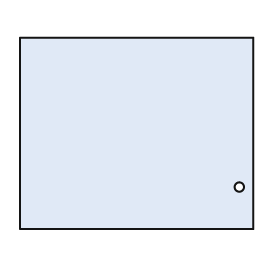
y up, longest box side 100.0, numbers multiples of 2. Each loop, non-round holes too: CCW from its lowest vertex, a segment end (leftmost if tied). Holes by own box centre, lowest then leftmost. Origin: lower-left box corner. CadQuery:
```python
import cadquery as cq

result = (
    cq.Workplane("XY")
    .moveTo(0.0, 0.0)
    .lineTo(100.0, 0.0)
    .lineTo(100.0, 82.0)
    .lineTo(0.0, 82.0)
    .close()
    .moveTo(94.0, 18.0)
    .circle(2.0)
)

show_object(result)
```